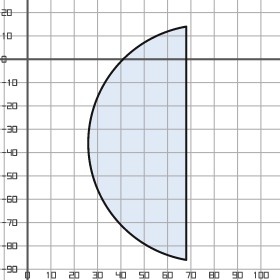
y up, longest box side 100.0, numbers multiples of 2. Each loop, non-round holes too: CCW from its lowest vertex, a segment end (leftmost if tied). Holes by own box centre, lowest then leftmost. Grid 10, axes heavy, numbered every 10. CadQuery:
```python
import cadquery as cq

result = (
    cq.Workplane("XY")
    .moveTo(68.0, -86.0)
    .lineTo(68.0, 14.0)
    .threePointArc((26.0, -36.0), (68.0, -86.0))
    .close()
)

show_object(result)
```